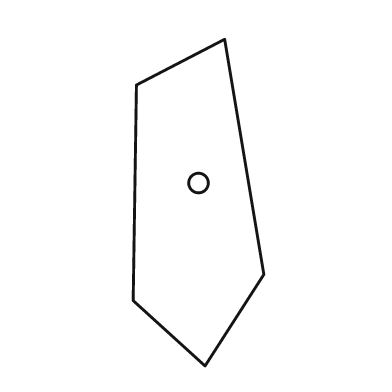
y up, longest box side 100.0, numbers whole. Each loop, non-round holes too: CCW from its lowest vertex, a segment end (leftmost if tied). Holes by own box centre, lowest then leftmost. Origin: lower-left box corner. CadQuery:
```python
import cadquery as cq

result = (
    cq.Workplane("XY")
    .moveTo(22.0, 0.0)
    .lineTo(40.0, 28.0)
    .lineTo(28.0, 100.0)
    .lineTo(1.0, 86.0)
    .lineTo(0.0, 20.0)
    .close()
    .moveTo(20.0, 56.0)
    .circle(3.0)
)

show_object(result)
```